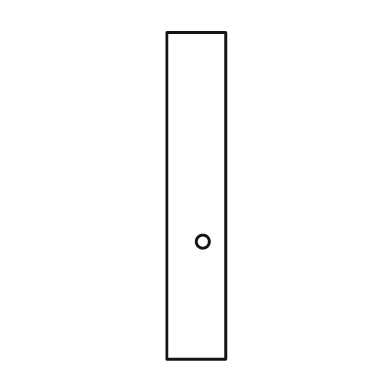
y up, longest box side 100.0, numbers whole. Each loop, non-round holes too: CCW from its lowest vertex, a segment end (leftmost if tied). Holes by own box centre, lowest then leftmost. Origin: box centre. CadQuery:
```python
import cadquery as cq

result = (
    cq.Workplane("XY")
    .moveTo(-9.0, -50.0)
    .lineTo(9.0, -50.0)
    .lineTo(9.0, 50.0)
    .lineTo(-9.0, 50.0)
    .close()
    .moveTo(2.0, -14.0)
    .circle(2.0)
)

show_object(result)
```